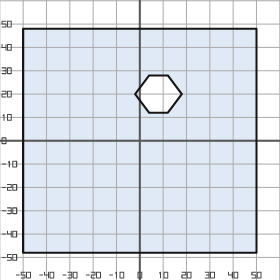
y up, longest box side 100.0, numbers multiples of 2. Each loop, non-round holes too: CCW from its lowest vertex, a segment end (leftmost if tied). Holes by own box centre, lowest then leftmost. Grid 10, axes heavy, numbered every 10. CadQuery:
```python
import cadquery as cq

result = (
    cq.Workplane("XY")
    .moveTo(-50.0, -48.0)
    .lineTo(50.0, -48.0)
    .lineTo(50.0, 48.0)
    .lineTo(-50.0, 48.0)
    .close()
    .moveTo(4.0, 12.0)
    .lineTo(12.0, 12.0)
    .lineTo(18.0, 20.0)
    .lineTo(12.0, 28.0)
    .lineTo(4.0, 28.0)
    .lineTo(-2.0, 20.0)
    .close()
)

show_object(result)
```